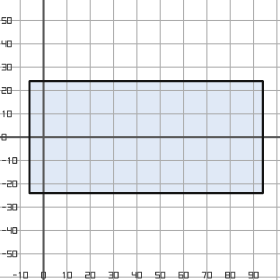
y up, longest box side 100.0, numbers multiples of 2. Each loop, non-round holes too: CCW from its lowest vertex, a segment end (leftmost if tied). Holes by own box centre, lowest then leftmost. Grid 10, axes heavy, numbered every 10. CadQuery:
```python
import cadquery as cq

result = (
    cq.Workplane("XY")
    .moveTo(-6.0, -24.0)
    .lineTo(94.0, -24.0)
    .lineTo(94.0, 24.0)
    .lineTo(-6.0, 24.0)
    .close()
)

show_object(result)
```